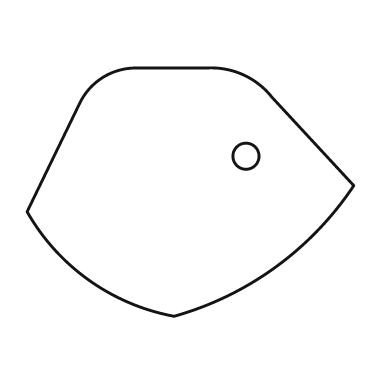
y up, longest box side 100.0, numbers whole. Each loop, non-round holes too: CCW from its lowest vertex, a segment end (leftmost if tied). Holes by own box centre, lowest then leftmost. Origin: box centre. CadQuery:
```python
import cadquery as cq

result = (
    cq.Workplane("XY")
    .moveTo(-5.0, -38.0)
    .threePointArc((26.0, -23.0), (50.0, 2.0))
    .lineTo(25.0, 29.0)
    .threePointArc((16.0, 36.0), (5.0, 38.0))
    .lineTo(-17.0, 38.0)
    .threePointArc((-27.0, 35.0), (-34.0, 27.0))
    .lineTo(-50.0, -6.0)
    .threePointArc((-31.0, -27.0), (-5.0, -38.0))
    .close()
    .moveTo(17.0, 11.0)
    .circle(4.0)
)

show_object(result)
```